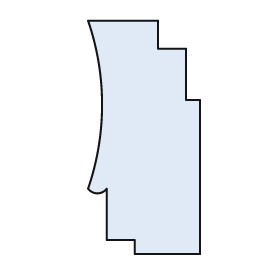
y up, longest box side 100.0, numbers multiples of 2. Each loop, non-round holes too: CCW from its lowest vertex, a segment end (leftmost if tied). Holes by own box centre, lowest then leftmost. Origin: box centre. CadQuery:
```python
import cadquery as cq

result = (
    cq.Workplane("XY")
    .moveTo(-4.0, -50.0)
    .lineTo(24.0, -50.0)
    .lineTo(24.0, 16.0)
    .lineTo(18.0, 16.0)
    .lineTo(18.0, 38.0)
    .lineTo(6.0, 38.0)
    .lineTo(6.0, 50.0)
    .lineTo(-24.0, 50.0)
    .threePointArc((-18.0, 14.0), (-24.0, -22.0))
    .threePointArc((-20.0, -24.0), (-16.0, -22.0))
    .lineTo(-16.0, -44.0)
    .lineTo(-4.0, -44.0)
    .close()
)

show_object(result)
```